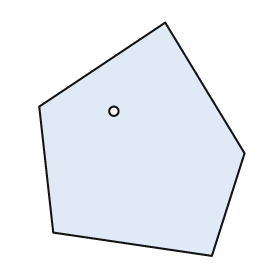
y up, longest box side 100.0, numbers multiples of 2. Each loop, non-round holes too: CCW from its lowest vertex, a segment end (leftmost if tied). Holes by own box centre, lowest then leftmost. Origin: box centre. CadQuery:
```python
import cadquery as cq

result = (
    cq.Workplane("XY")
    .moveTo(30.0, -50.0)
    .lineTo(44.0, -6.0)
    .lineTo(10.0, 50.0)
    .lineTo(-44.0, 14.0)
    .lineTo(-38.0, -40.0)
    .close()
    .moveTo(-12.0, 12.0)
    .circle(2.0)
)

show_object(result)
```